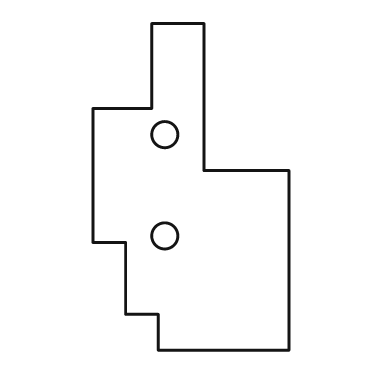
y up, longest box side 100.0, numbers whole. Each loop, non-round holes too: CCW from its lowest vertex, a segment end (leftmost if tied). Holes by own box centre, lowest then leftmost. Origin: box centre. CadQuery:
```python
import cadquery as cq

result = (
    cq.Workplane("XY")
    .moveTo(-10.0, -50.0)
    .lineTo(30.0, -50.0)
    .lineTo(30.0, 5.0)
    .lineTo(4.0, 5.0)
    .lineTo(4.0, 50.0)
    .lineTo(-12.0, 50.0)
    .lineTo(-12.0, 24.0)
    .lineTo(-30.0, 24.0)
    .lineTo(-30.0, -17.0)
    .lineTo(-20.0, -17.0)
    .lineTo(-20.0, -39.0)
    .lineTo(-10.0, -39.0)
    .close()
    .moveTo(-8.0, -15.0)
    .circle(4.0)
    .moveTo(-8.0, 16.0)
    .circle(4.0)
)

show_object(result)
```